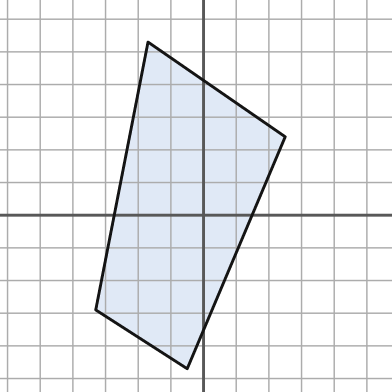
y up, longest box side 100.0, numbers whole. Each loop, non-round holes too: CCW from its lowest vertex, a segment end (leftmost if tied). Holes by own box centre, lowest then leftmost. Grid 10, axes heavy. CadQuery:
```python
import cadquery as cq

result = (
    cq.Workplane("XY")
    .moveTo(-5.0, -47.0)
    .lineTo(25.0, 24.0)
    .lineTo(-17.0, 53.0)
    .lineTo(-33.0, -29.0)
    .close()
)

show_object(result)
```